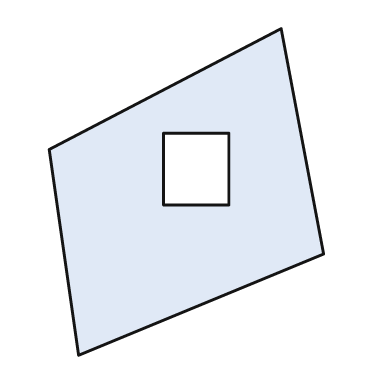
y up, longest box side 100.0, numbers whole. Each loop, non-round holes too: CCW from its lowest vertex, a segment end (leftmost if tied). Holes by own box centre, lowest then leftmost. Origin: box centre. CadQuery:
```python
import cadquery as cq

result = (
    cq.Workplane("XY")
    .moveTo(-33.0, -50.0)
    .lineTo(42.0, -19.0)
    .lineTo(29.0, 50.0)
    .lineTo(-42.0, 13.0)
    .close()
    .moveTo(-7.0, -4.0)
    .lineTo(13.0, -4.0)
    .lineTo(13.0, 18.0)
    .lineTo(-7.0, 18.0)
    .close()
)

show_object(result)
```